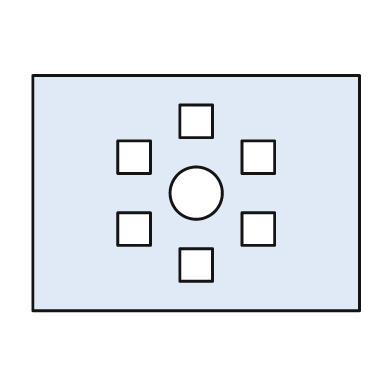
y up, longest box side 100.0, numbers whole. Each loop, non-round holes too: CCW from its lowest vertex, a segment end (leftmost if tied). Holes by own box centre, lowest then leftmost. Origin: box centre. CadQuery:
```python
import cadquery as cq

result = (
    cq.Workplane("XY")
    .moveTo(-50.0, -36.0)
    .lineTo(50.0, -36.0)
    .lineTo(50.0, 36.0)
    .lineTo(-50.0, 36.0)
    .close()
    .moveTo(-5.0, -27.0)
    .lineTo(5.0, -27.0)
    .lineTo(5.0, -17.0)
    .lineTo(-5.0, -17.0)
    .close()
    .moveTo(-24.0, -16.0)
    .lineTo(-14.0, -16.0)
    .lineTo(-14.0, -6.0)
    .lineTo(-24.0, -6.0)
    .close()
    .moveTo(14.0, -16.0)
    .lineTo(24.0, -16.0)
    .lineTo(24.0, -6.0)
    .lineTo(14.0, -6.0)
    .close()
    .moveTo(0.0, 0.0)
    .circle(8.0)
    .moveTo(-24.0, 6.0)
    .lineTo(-14.0, 6.0)
    .lineTo(-14.0, 16.0)
    .lineTo(-24.0, 16.0)
    .close()
    .moveTo(14.0, 6.0)
    .lineTo(24.0, 6.0)
    .lineTo(24.0, 16.0)
    .lineTo(14.0, 16.0)
    .close()
    .moveTo(-5.0, 17.0)
    .lineTo(5.0, 17.0)
    .lineTo(5.0, 27.0)
    .lineTo(-5.0, 27.0)
    .close()
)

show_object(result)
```